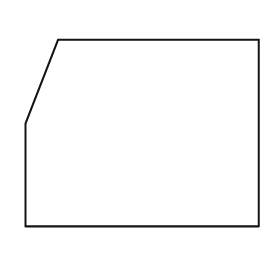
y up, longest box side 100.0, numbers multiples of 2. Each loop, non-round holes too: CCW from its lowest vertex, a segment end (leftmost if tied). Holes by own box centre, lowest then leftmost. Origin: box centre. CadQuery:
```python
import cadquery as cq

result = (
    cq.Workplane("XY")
    .moveTo(-50.0, -40.0)
    .lineTo(50.0, -40.0)
    .lineTo(50.0, 40.0)
    .lineTo(-36.0, 40.0)
    .lineTo(-50.0, 4.0)
    .close()
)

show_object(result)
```